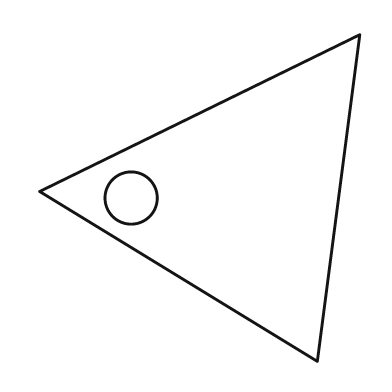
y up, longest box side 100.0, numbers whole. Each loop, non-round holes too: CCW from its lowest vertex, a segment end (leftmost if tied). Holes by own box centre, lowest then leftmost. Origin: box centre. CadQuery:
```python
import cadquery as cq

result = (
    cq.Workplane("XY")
    .moveTo(36.0, -50.0)
    .lineTo(49.0, 50.0)
    .lineTo(-49.0, 2.0)
    .close()
    .moveTo(-21.0, 0.0)
    .circle(8.0)
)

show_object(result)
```